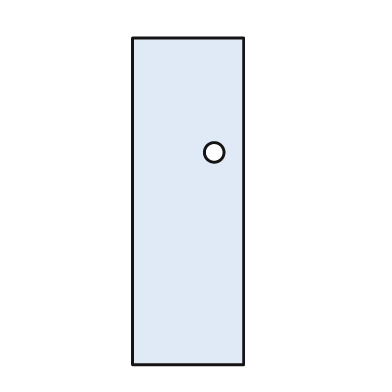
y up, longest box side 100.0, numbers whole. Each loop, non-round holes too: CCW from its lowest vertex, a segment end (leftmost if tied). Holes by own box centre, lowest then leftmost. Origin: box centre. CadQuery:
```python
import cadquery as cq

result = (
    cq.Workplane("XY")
    .moveTo(-17.0, -50.0)
    .lineTo(17.0, -50.0)
    .lineTo(17.0, 50.0)
    .lineTo(-17.0, 50.0)
    .close()
    .moveTo(8.0, 15.0)
    .circle(3.0)
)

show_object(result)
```